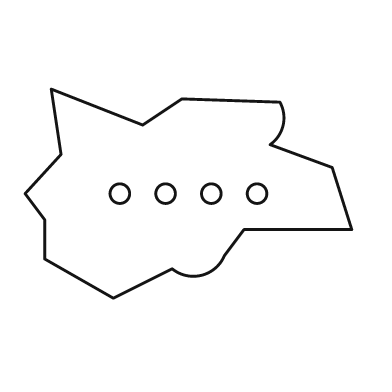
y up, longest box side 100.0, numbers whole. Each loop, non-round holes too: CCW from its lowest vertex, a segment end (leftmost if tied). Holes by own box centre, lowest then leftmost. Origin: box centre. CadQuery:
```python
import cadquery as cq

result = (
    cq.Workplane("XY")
    .moveTo(-23.0, -32.0)
    .lineTo(-5.0, -23.0)
    .threePointArc((4.0, -25.0), (11.0, -19.0))
    .lineTo(17.0, -11.0)
    .lineTo(50.0, -11.0)
    .lineTo(44.0, 8.0)
    .lineTo(25.0, 15.0)
    .threePointArc((29.0, 21.0), (28.0, 28.0))
    .lineTo(-2.0, 29.0)
    .lineTo(-14.0, 21.0)
    .lineTo(-42.0, 32.0)
    .lineTo(-39.0, 12.0)
    .lineTo(-50.0, 0.0)
    .lineTo(-44.0, -8.0)
    .lineTo(-44.0, -20.0)
    .close()
    .moveTo(-21.0, 0.0)
    .circle(3.0)
    .moveTo(-7.0, 0.0)
    .circle(3.0)
    .moveTo(7.0, 0.0)
    .circle(3.0)
    .moveTo(21.0, 0.0)
    .circle(3.0)
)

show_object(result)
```